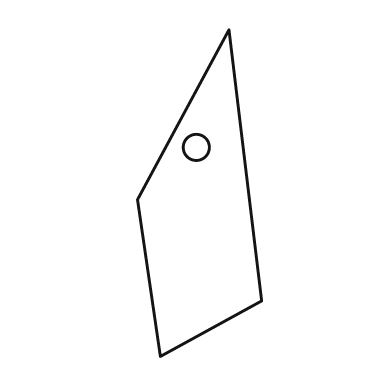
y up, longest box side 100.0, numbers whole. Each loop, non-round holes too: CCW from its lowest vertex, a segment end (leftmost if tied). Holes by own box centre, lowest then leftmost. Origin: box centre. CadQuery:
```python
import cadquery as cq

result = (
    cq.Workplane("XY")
    .moveTo(-12.0, -50.0)
    .lineTo(19.0, -33.0)
    .lineTo(9.0, 50.0)
    .lineTo(-19.0, -2.0)
    .close()
    .moveTo(-1.0, 14.0)
    .circle(4.0)
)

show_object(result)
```